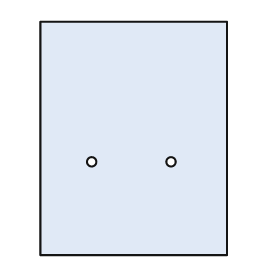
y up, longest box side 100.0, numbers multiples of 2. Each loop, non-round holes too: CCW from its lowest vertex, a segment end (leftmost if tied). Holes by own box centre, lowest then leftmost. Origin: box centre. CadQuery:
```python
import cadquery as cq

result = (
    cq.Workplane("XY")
    .moveTo(-40.0, -50.0)
    .lineTo(40.0, -50.0)
    .lineTo(40.0, 50.0)
    .lineTo(-40.0, 50.0)
    .close()
    .moveTo(-18.0, -10.0)
    .circle(2.0)
    .moveTo(16.0, -10.0)
    .circle(2.0)
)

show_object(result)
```